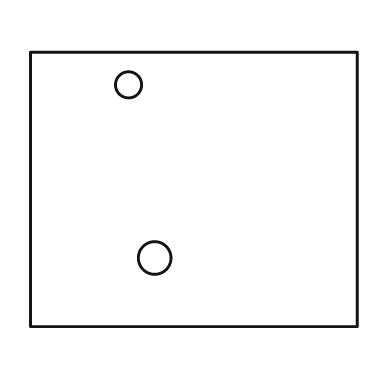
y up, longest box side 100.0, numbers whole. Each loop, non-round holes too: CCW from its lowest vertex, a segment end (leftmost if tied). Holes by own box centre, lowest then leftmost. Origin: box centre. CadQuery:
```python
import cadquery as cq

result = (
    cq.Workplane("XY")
    .moveTo(-50.0, -42.0)
    .lineTo(50.0, -42.0)
    .lineTo(50.0, 42.0)
    .lineTo(-50.0, 42.0)
    .close()
    .moveTo(-12.0, -21.0)
    .circle(5.0)
    .moveTo(-20.0, 32.0)
    .circle(4.0)
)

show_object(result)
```